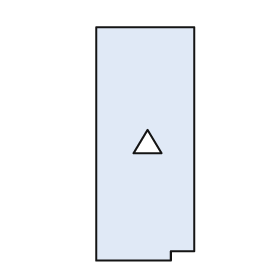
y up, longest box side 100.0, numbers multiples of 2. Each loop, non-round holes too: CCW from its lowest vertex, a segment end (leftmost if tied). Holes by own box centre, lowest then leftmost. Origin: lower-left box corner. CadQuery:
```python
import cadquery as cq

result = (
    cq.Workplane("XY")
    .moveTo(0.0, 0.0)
    .lineTo(32.0, 0.0)
    .lineTo(32.0, 4.0)
    .lineTo(42.0, 4.0)
    .lineTo(42.0, 100.0)
    .lineTo(0.0, 100.0)
    .close()
    .moveTo(16.0, 46.0)
    .lineTo(28.0, 46.0)
    .lineTo(22.0, 56.0)
    .close()
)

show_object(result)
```